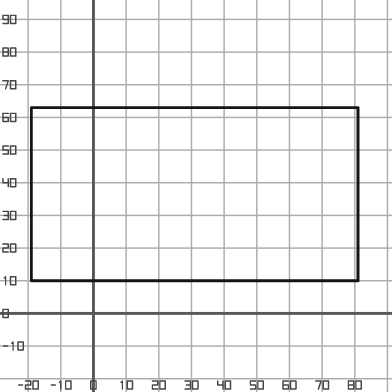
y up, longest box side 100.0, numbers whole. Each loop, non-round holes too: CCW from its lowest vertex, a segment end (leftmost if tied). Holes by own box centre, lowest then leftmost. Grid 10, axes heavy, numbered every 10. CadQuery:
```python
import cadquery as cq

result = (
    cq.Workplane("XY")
    .moveTo(-19.0, 10.0)
    .lineTo(81.0, 10.0)
    .lineTo(81.0, 63.0)
    .lineTo(-19.0, 63.0)
    .close()
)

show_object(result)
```